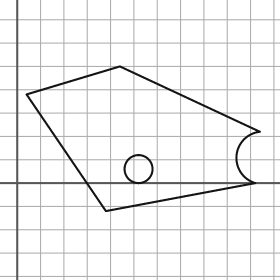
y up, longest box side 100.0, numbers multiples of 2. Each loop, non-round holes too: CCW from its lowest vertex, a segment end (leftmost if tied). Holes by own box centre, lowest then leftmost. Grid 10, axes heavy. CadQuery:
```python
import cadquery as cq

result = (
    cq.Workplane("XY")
    .moveTo(38.0, -12.0)
    .lineTo(102.0, 0.0)
    .threePointArc((94.0, 12.0), (104.0, 22.0))
    .lineTo(44.0, 50.0)
    .lineTo(4.0, 38.0)
    .close()
    .moveTo(52.0, 6.0)
    .circle(6.0)
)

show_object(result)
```